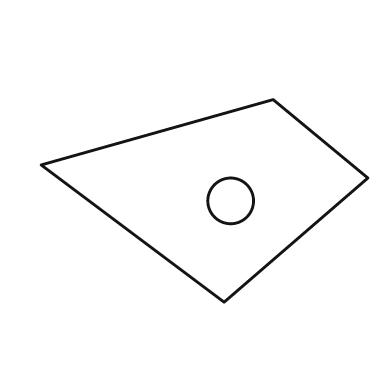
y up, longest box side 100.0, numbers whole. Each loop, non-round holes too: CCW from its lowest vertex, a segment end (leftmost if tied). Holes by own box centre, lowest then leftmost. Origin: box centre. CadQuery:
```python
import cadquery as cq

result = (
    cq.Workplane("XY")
    .moveTo(6.0, -31.0)
    .lineTo(50.0, 7.0)
    .lineTo(21.0, 31.0)
    .lineTo(-50.0, 11.0)
    .close()
    .moveTo(8.0, 0.0)
    .circle(7.0)
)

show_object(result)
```